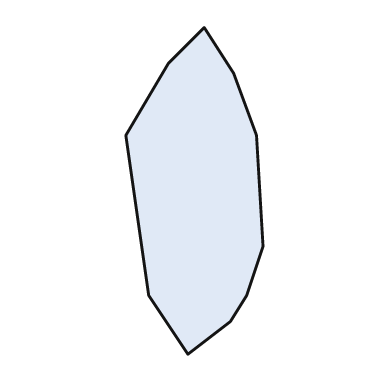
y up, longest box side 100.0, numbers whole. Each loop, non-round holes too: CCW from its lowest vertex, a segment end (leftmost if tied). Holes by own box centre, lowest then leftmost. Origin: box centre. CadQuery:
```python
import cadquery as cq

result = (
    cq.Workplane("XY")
    .moveTo(-2.0, -50.0)
    .lineTo(11.0, -40.0)
    .lineTo(16.0, -32.0)
    .lineTo(21.0, -17.0)
    .lineTo(19.0, 17.0)
    .lineTo(12.0, 36.0)
    .lineTo(3.0, 50.0)
    .lineTo(-8.0, 39.0)
    .lineTo(-21.0, 17.0)
    .lineTo(-14.0, -32.0)
    .close()
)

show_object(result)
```